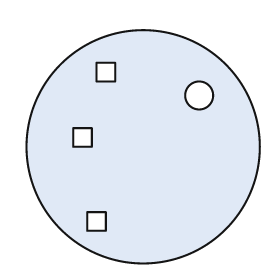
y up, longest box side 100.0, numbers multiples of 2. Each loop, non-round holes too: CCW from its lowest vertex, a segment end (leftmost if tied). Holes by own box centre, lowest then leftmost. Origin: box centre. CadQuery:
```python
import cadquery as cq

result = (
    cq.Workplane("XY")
    .moveTo(0.0, 0.0)
    .circle(50.0)
    .moveTo(-24.0, -36.0)
    .lineTo(-16.0, -36.0)
    .lineTo(-16.0, -28.0)
    .lineTo(-24.0, -28.0)
    .close()
    .moveTo(-30.0, 0.0)
    .lineTo(-22.0, 0.0)
    .lineTo(-22.0, 8.0)
    .lineTo(-30.0, 8.0)
    .close()
    .moveTo(24.0, 22.0)
    .circle(6.0)
    .moveTo(-20.0, 28.0)
    .lineTo(-12.0, 28.0)
    .lineTo(-12.0, 36.0)
    .lineTo(-20.0, 36.0)
    .close()
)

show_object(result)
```